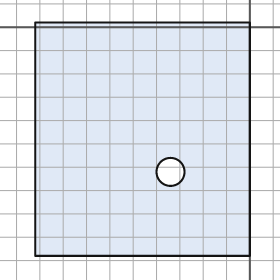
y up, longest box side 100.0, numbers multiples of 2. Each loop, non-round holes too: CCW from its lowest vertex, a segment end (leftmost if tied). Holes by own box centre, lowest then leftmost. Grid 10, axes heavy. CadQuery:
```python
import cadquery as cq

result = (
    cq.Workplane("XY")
    .moveTo(-92.0, -98.0)
    .lineTo(0.0, -98.0)
    .lineTo(0.0, 2.0)
    .lineTo(-92.0, 2.0)
    .close()
    .moveTo(-34.0, -62.0)
    .circle(6.0)
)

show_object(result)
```